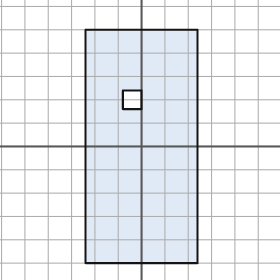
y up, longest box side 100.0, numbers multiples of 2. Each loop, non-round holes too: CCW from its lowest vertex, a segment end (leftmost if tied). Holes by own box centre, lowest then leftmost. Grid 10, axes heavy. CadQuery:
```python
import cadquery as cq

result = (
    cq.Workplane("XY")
    .moveTo(-24.0, -50.0)
    .lineTo(24.0, -50.0)
    .lineTo(24.0, 50.0)
    .lineTo(-24.0, 50.0)
    .close()
    .moveTo(-8.0, 16.0)
    .lineTo(0.0, 16.0)
    .lineTo(0.0, 24.0)
    .lineTo(-8.0, 24.0)
    .close()
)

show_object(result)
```